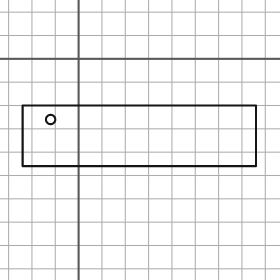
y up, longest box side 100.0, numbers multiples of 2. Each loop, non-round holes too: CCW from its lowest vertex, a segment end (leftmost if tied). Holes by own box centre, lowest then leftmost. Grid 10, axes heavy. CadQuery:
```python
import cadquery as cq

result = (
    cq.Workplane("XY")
    .moveTo(-24.0, -46.0)
    .lineTo(76.0, -46.0)
    .lineTo(76.0, -20.0)
    .lineTo(-24.0, -20.0)
    .close()
    .moveTo(-12.0, -26.0)
    .circle(2.0)
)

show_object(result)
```